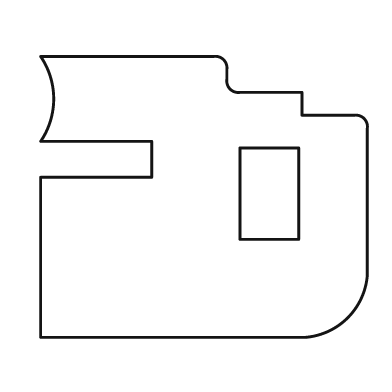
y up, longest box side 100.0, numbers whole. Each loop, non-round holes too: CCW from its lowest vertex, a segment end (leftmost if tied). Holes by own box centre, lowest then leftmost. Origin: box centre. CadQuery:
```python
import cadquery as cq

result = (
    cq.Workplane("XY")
    .moveTo(-50.0, -43.0)
    .lineTo(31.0, -43.0)
    .threePointArc((44.0, -37.0), (50.0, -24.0))
    .lineTo(50.0, 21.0)
    .threePointArc((49.0, 24.0), (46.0, 25.0))
    .lineTo(30.0, 25.0)
    .lineTo(30.0, 32.0)
    .lineTo(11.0, 32.0)
    .threePointArc((8.0, 33.0), (7.0, 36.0))
    .lineTo(7.0, 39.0)
    .threePointArc((6.0, 42.0), (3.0, 43.0))
    .lineTo(-50.0, 43.0)
    .threePointArc((-46.0, 30.0), (-50.0, 17.0))
    .lineTo(-16.0, 17.0)
    .lineTo(-16.0, 6.0)
    .lineTo(-50.0, 6.0)
    .close()
    .moveTo(11.0, -13.0)
    .lineTo(29.0, -13.0)
    .lineTo(29.0, 15.0)
    .lineTo(11.0, 15.0)
    .close()
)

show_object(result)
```